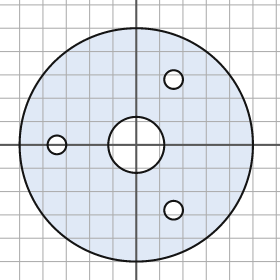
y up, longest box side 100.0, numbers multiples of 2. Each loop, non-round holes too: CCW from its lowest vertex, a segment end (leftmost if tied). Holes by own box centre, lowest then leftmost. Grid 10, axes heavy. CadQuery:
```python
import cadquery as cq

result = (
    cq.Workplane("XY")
    .moveTo(0.0, 0.0)
    .circle(50.0)
    .moveTo(16.0, -28.0)
    .circle(4.0)
    .moveTo(-34.0, 0.0)
    .circle(4.0)
    .moveTo(0.0, 0.0)
    .circle(12.0)
    .moveTo(16.0, 28.0)
    .circle(4.0)
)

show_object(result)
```